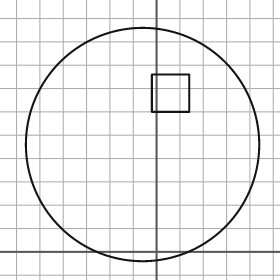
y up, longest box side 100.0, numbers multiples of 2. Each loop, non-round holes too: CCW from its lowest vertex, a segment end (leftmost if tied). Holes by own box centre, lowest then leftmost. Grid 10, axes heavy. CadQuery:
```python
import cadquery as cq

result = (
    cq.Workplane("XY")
    .moveTo(-6.0, 46.0)
    .circle(50.0)
    .moveTo(-2.0, 60.0)
    .lineTo(14.0, 60.0)
    .lineTo(14.0, 76.0)
    .lineTo(-2.0, 76.0)
    .close()
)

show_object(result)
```